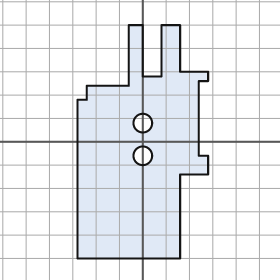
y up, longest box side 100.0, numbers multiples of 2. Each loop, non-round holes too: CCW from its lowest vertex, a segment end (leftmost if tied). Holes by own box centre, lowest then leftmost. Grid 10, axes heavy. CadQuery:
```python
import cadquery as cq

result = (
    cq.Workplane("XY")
    .moveTo(-28.0, -50.0)
    .lineTo(16.0, -50.0)
    .lineTo(16.0, -14.0)
    .lineTo(28.0, -14.0)
    .lineTo(28.0, -6.0)
    .lineTo(24.0, -6.0)
    .lineTo(24.0, 26.0)
    .lineTo(28.0, 26.0)
    .lineTo(28.0, 30.0)
    .lineTo(16.0, 30.0)
    .lineTo(16.0, 50.0)
    .lineTo(8.0, 50.0)
    .lineTo(8.0, 28.0)
    .lineTo(0.0, 28.0)
    .lineTo(0.0, 50.0)
    .lineTo(-6.0, 50.0)
    .lineTo(-6.0, 24.0)
    .lineTo(-24.0, 24.0)
    .lineTo(-24.0, 18.0)
    .lineTo(-28.0, 18.0)
    .close()
    .moveTo(0.0, -6.0)
    .circle(4.0)
    .moveTo(0.0, 8.0)
    .circle(4.0)
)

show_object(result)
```